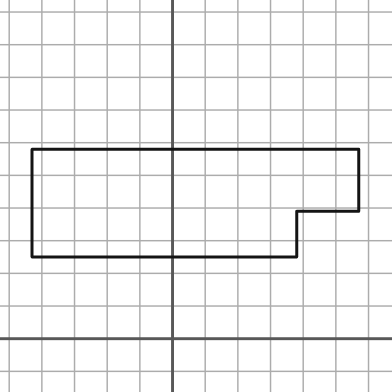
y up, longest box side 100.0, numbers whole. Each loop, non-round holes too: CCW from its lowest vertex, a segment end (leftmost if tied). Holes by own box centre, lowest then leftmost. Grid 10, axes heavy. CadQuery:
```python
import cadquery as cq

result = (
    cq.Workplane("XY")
    .moveTo(-43.0, 25.0)
    .lineTo(38.0, 25.0)
    .lineTo(38.0, 39.0)
    .lineTo(57.0, 39.0)
    .lineTo(57.0, 58.0)
    .lineTo(-43.0, 58.0)
    .close()
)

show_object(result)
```